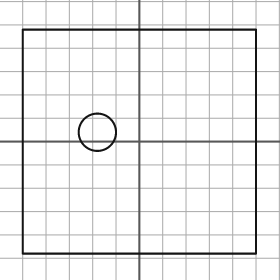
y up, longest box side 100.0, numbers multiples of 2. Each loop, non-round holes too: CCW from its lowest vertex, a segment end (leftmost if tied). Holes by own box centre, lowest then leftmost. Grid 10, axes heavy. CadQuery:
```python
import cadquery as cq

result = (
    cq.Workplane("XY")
    .moveTo(-50.0, -48.0)
    .lineTo(50.0, -48.0)
    .lineTo(50.0, 48.0)
    .lineTo(-50.0, 48.0)
    .close()
    .moveTo(-18.0, 4.0)
    .circle(8.0)
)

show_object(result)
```